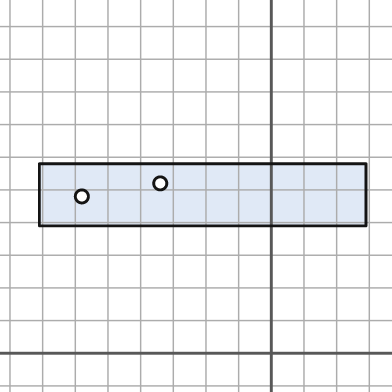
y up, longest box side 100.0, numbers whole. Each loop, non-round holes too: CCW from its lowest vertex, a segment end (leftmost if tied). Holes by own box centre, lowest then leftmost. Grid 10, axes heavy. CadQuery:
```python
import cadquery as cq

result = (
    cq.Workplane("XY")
    .moveTo(-71.0, 39.0)
    .lineTo(29.0, 39.0)
    .lineTo(29.0, 58.0)
    .lineTo(-71.0, 58.0)
    .close()
    .moveTo(-58.0, 48.0)
    .circle(2.0)
    .moveTo(-34.0, 52.0)
    .circle(2.0)
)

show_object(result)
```